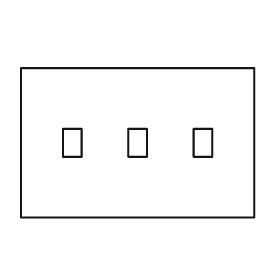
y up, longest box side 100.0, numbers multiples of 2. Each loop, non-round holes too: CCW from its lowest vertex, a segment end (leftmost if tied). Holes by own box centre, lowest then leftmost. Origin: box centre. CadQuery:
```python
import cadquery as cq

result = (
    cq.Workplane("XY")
    .moveTo(-50.0, -32.0)
    .lineTo(50.0, -32.0)
    .lineTo(50.0, 32.0)
    .lineTo(-50.0, 32.0)
    .close()
    .moveTo(-32.0, -6.0)
    .lineTo(-24.0, -6.0)
    .lineTo(-24.0, 6.0)
    .lineTo(-32.0, 6.0)
    .close()
    .moveTo(-4.0, -6.0)
    .lineTo(4.0, -6.0)
    .lineTo(4.0, 6.0)
    .lineTo(-4.0, 6.0)
    .close()
    .moveTo(24.0, -6.0)
    .lineTo(32.0, -6.0)
    .lineTo(32.0, 6.0)
    .lineTo(24.0, 6.0)
    .close()
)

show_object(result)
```